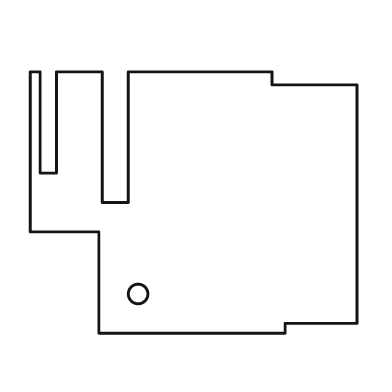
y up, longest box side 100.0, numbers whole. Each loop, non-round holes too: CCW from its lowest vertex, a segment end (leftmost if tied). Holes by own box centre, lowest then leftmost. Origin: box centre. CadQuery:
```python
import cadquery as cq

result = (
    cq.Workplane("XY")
    .moveTo(-29.0, -40.0)
    .lineTo(28.0, -40.0)
    .lineTo(28.0, -37.0)
    .lineTo(50.0, -37.0)
    .lineTo(50.0, 36.0)
    .lineTo(24.0, 36.0)
    .lineTo(24.0, 40.0)
    .lineTo(-20.0, 40.0)
    .lineTo(-20.0, 0.0)
    .lineTo(-28.0, 0.0)
    .lineTo(-28.0, 40.0)
    .lineTo(-42.0, 40.0)
    .lineTo(-42.0, 9.0)
    .lineTo(-47.0, 9.0)
    .lineTo(-47.0, 40.0)
    .lineTo(-50.0, 40.0)
    .lineTo(-50.0, -9.0)
    .lineTo(-29.0, -9.0)
    .close()
    .moveTo(-17.0, -28.0)
    .circle(3.0)
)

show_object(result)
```